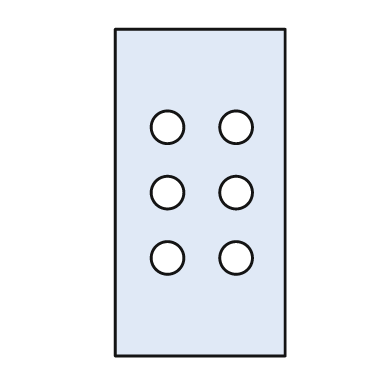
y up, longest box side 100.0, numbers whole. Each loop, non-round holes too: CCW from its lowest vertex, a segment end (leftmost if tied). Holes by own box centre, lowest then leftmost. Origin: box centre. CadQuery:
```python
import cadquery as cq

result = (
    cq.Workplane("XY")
    .moveTo(-26.0, -50.0)
    .lineTo(26.0, -50.0)
    .lineTo(26.0, 50.0)
    .lineTo(-26.0, 50.0)
    .close()
    .moveTo(-10.0, -20.0)
    .circle(5.0)
    .moveTo(11.0, -20.0)
    .circle(5.0)
    .moveTo(-10.0, 0.0)
    .circle(5.0)
    .moveTo(11.0, 0.0)
    .circle(5.0)
    .moveTo(-10.0, 20.0)
    .circle(5.0)
    .moveTo(11.0, 20.0)
    .circle(5.0)
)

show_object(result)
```